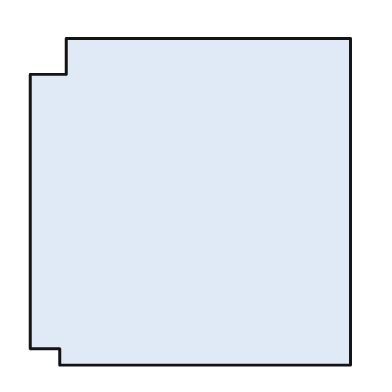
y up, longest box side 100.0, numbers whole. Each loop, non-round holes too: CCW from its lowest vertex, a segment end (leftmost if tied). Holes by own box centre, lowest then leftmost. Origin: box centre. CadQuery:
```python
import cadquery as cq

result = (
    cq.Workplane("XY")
    .moveTo(-40.0, -50.0)
    .lineTo(49.0, -50.0)
    .lineTo(49.0, 50.0)
    .lineTo(-38.0, 50.0)
    .lineTo(-38.0, 39.0)
    .lineTo(-49.0, 39.0)
    .lineTo(-49.0, -45.0)
    .lineTo(-40.0, -45.0)
    .close()
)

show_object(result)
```